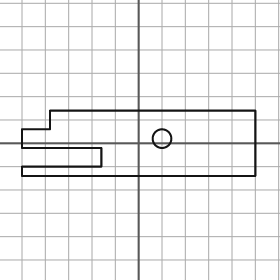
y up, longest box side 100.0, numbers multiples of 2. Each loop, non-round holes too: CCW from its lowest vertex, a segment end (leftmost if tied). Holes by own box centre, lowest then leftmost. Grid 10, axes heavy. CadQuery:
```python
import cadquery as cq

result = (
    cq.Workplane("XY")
    .moveTo(-50.0, -14.0)
    .lineTo(50.0, -14.0)
    .lineTo(50.0, 14.0)
    .lineTo(-38.0, 14.0)
    .lineTo(-38.0, 6.0)
    .lineTo(-50.0, 6.0)
    .lineTo(-50.0, -2.0)
    .lineTo(-16.0, -2.0)
    .lineTo(-16.0, -10.0)
    .lineTo(-50.0, -10.0)
    .close()
    .moveTo(10.0, 2.0)
    .circle(4.0)
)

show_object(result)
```